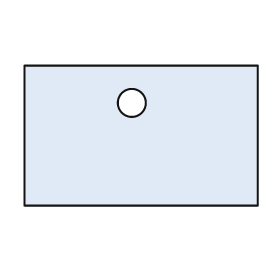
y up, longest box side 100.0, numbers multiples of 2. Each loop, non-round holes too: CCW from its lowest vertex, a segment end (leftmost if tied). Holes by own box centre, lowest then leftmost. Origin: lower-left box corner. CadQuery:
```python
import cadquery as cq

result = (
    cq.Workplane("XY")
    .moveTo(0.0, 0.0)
    .lineTo(100.0, 0.0)
    .lineTo(100.0, 60.0)
    .lineTo(0.0, 60.0)
    .close()
    .moveTo(46.0, 44.0)
    .circle(6.0)
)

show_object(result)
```